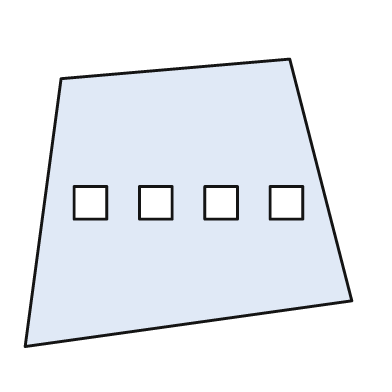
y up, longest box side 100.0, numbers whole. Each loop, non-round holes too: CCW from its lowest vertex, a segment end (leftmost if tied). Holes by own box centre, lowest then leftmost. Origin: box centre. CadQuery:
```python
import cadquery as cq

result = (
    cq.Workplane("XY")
    .moveTo(-50.0, -44.0)
    .lineTo(50.0, -30.0)
    .lineTo(31.0, 44.0)
    .lineTo(-39.0, 38.0)
    .close()
    .moveTo(-35.0, -5.0)
    .lineTo(-25.0, -5.0)
    .lineTo(-25.0, 5.0)
    .lineTo(-35.0, 5.0)
    .close()
    .moveTo(-15.0, -5.0)
    .lineTo(-5.0, -5.0)
    .lineTo(-5.0, 5.0)
    .lineTo(-15.0, 5.0)
    .close()
    .moveTo(5.0, -5.0)
    .lineTo(15.0, -5.0)
    .lineTo(15.0, 5.0)
    .lineTo(5.0, 5.0)
    .close()
    .moveTo(25.0, -5.0)
    .lineTo(35.0, -5.0)
    .lineTo(35.0, 5.0)
    .lineTo(25.0, 5.0)
    .close()
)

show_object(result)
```